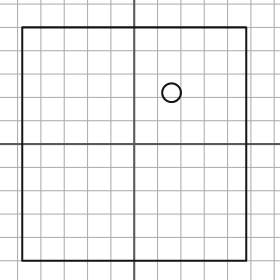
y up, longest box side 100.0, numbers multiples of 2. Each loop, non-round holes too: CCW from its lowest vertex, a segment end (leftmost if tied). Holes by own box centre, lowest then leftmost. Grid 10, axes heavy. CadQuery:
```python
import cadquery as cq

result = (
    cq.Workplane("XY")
    .moveTo(-48.0, -50.0)
    .lineTo(48.0, -50.0)
    .lineTo(48.0, 50.0)
    .lineTo(-48.0, 50.0)
    .close()
    .moveTo(16.0, 22.0)
    .circle(4.0)
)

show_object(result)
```